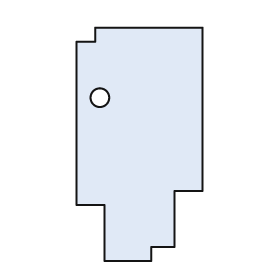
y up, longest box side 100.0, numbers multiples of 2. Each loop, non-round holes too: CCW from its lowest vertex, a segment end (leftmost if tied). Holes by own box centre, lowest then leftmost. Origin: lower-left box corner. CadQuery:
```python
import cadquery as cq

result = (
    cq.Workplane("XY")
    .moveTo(12.0, 0.0)
    .lineTo(32.0, 0.0)
    .lineTo(32.0, 6.0)
    .lineTo(42.0, 6.0)
    .lineTo(42.0, 30.0)
    .lineTo(54.0, 30.0)
    .lineTo(54.0, 100.0)
    .lineTo(8.0, 100.0)
    .lineTo(8.0, 94.0)
    .lineTo(0.0, 94.0)
    .lineTo(0.0, 24.0)
    .lineTo(12.0, 24.0)
    .close()
    .moveTo(10.0, 70.0)
    .circle(4.0)
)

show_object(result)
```